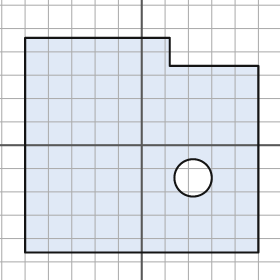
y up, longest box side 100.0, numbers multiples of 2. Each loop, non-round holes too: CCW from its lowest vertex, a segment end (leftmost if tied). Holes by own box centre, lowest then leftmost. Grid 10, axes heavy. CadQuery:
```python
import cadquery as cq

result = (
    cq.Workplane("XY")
    .moveTo(-50.0, -46.0)
    .lineTo(50.0, -46.0)
    .lineTo(50.0, 34.0)
    .lineTo(12.0, 34.0)
    .lineTo(12.0, 46.0)
    .lineTo(-50.0, 46.0)
    .close()
    .moveTo(22.0, -14.0)
    .circle(8.0)
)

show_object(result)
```